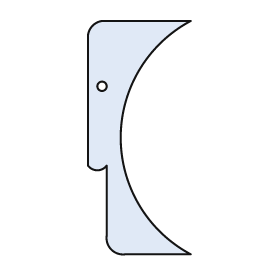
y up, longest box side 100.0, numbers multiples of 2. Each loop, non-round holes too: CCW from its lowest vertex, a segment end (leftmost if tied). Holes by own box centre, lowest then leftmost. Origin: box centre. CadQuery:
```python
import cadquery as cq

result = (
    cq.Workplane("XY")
    .moveTo(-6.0, -50.0)
    .lineTo(22.0, -50.0)
    .threePointArc((-8.0, 0.0), (22.0, 50.0))
    .lineTo(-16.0, 50.0)
    .threePointArc((-20.0, 48.0), (-22.0, 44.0))
    .lineTo(-22.0, -12.0)
    .threePointArc((-18.0, -14.0), (-14.0, -12.0))
    .lineTo(-14.0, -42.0)
    .threePointArc((-12.0, -48.0), (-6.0, -50.0))
    .close()
    .moveTo(-16.0, 22.0)
    .circle(2.0)
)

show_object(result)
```